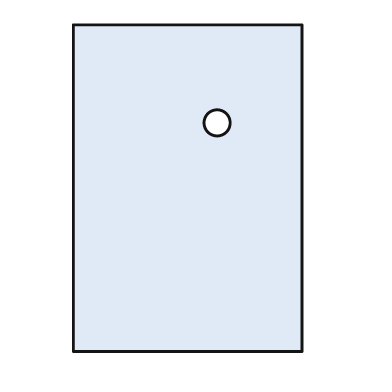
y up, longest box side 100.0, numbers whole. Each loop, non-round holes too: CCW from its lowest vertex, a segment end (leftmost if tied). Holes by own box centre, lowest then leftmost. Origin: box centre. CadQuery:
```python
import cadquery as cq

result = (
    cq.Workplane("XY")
    .moveTo(-35.0, -50.0)
    .lineTo(35.0, -50.0)
    .lineTo(35.0, 50.0)
    .lineTo(-35.0, 50.0)
    .close()
    .moveTo(9.0, 20.0)
    .circle(4.0)
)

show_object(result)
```